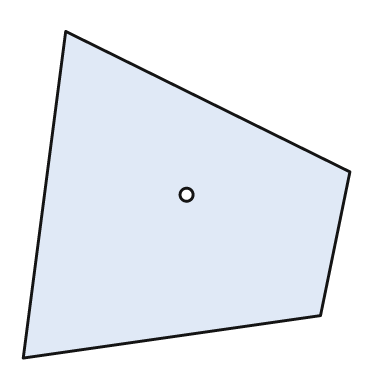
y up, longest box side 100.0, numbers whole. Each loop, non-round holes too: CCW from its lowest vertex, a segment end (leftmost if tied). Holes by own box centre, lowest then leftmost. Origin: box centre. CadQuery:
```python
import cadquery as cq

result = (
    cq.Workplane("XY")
    .moveTo(-50.0, -50.0)
    .lineTo(41.0, -37.0)
    .lineTo(50.0, 7.0)
    .lineTo(-37.0, 50.0)
    .close()
    .moveTo(0.0, 0.0)
    .circle(2.0)
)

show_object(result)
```